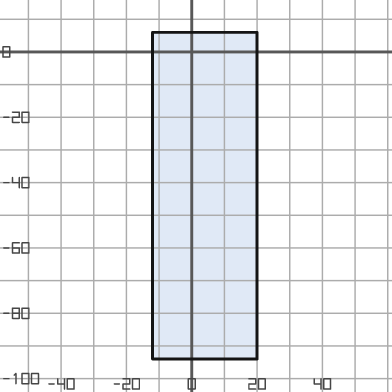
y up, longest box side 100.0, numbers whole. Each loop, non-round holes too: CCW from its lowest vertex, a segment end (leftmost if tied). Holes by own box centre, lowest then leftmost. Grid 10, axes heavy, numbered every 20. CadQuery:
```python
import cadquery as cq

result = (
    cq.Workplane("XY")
    .moveTo(-12.0, -94.0)
    .lineTo(20.0, -94.0)
    .lineTo(20.0, 6.0)
    .lineTo(-12.0, 6.0)
    .close()
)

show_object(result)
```